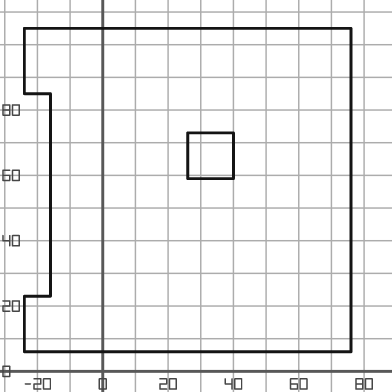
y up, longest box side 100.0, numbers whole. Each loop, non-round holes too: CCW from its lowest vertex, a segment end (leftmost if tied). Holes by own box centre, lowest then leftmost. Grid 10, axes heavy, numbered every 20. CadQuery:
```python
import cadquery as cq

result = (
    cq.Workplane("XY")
    .moveTo(-24.0, 6.0)
    .lineTo(76.0, 6.0)
    .lineTo(76.0, 105.0)
    .lineTo(-24.0, 105.0)
    .lineTo(-24.0, 85.0)
    .lineTo(-16.0, 85.0)
    .lineTo(-16.0, 23.0)
    .lineTo(-24.0, 23.0)
    .close()
    .moveTo(26.0, 59.0)
    .lineTo(40.0, 59.0)
    .lineTo(40.0, 73.0)
    .lineTo(26.0, 73.0)
    .close()
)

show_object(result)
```